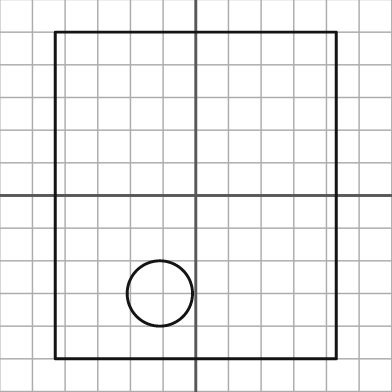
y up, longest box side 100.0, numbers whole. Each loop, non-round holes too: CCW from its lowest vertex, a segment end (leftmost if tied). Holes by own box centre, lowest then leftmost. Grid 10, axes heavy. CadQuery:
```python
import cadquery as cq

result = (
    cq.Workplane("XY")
    .moveTo(-43.0, -50.0)
    .lineTo(43.0, -50.0)
    .lineTo(43.0, 50.0)
    .lineTo(-43.0, 50.0)
    .close()
    .moveTo(-11.0, -30.0)
    .circle(10.0)
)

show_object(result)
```